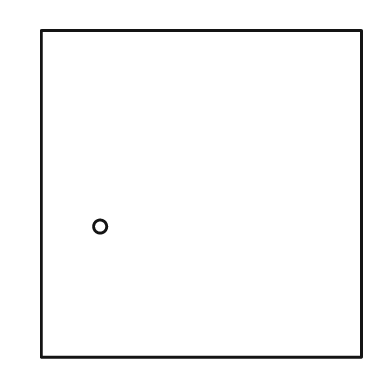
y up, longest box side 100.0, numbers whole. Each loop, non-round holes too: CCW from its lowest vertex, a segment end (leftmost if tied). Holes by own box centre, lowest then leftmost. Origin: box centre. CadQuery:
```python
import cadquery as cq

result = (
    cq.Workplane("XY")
    .moveTo(-49.0, -50.0)
    .lineTo(49.0, -50.0)
    .lineTo(49.0, 50.0)
    .lineTo(-49.0, 50.0)
    .close()
    .moveTo(-31.0, -10.0)
    .circle(2.0)
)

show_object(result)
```